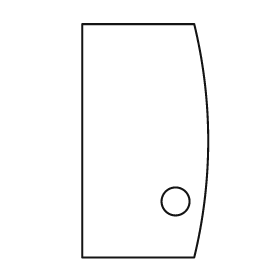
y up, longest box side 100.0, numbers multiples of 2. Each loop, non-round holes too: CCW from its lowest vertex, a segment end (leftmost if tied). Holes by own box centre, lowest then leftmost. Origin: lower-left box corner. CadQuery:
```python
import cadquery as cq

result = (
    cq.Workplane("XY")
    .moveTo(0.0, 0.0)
    .lineTo(48.0, 0.0)
    .threePointArc((54.0, 50.0), (48.0, 100.0))
    .lineTo(0.0, 100.0)
    .close()
    .moveTo(40.0, 24.0)
    .circle(6.0)
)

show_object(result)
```